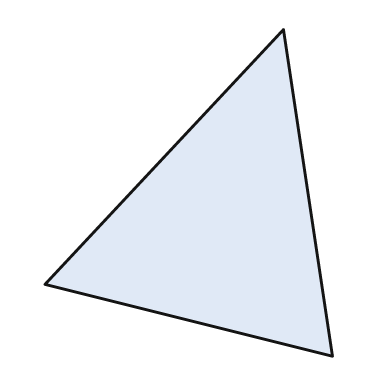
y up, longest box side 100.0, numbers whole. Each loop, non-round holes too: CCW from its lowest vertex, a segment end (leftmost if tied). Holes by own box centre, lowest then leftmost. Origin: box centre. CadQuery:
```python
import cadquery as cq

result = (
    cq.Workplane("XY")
    .moveTo(44.0, -50.0)
    .lineTo(29.0, 50.0)
    .lineTo(-44.0, -28.0)
    .close()
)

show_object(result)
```